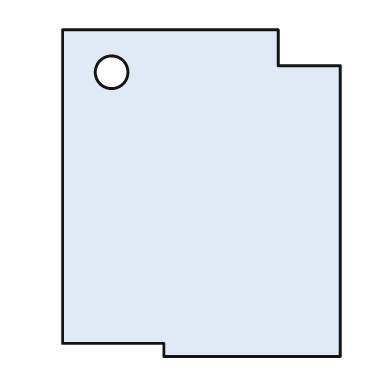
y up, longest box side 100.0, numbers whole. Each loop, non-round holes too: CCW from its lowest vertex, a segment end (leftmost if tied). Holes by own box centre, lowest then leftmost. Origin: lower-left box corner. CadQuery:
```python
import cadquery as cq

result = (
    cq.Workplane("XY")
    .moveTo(31.0, 0.0)
    .lineTo(85.0, 0.0)
    .lineTo(85.0, 89.0)
    .lineTo(66.0, 89.0)
    .lineTo(66.0, 100.0)
    .lineTo(0.0, 100.0)
    .lineTo(0.0, 4.0)
    .lineTo(31.0, 4.0)
    .close()
    .moveTo(15.0, 87.0)
    .circle(5.0)
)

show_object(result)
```